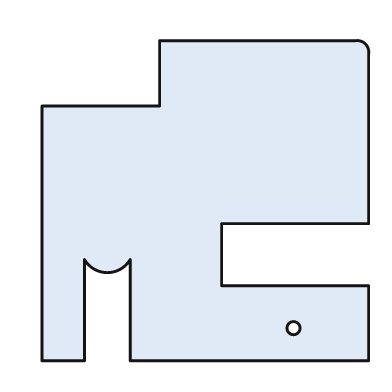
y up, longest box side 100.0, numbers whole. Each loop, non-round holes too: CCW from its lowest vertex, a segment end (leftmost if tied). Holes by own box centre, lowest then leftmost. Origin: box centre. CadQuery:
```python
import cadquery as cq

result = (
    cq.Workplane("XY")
    .moveTo(-50.0, -49.0)
    .lineTo(-37.0, -49.0)
    .lineTo(-37.0, -18.0)
    .threePointArc((-30.0, -22.0), (-23.0, -18.0))
    .lineTo(-23.0, -49.0)
    .lineTo(50.0, -49.0)
    .lineTo(50.0, -26.0)
    .lineTo(5.0, -26.0)
    .lineTo(5.0, -7.0)
    .lineTo(50.0, -7.0)
    .lineTo(50.0, 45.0)
    .threePointArc((49.0, 48.0), (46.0, 49.0))
    .lineTo(-14.0, 49.0)
    .lineTo(-14.0, 29.0)
    .lineTo(-50.0, 29.0)
    .close()
    .moveTo(27.0, -39.0)
    .circle(2.0)
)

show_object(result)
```